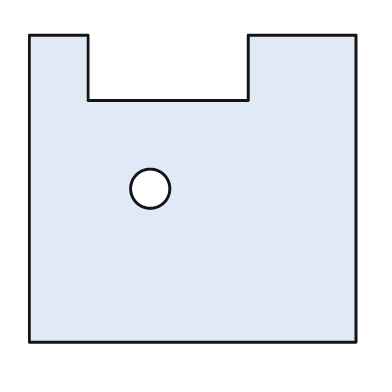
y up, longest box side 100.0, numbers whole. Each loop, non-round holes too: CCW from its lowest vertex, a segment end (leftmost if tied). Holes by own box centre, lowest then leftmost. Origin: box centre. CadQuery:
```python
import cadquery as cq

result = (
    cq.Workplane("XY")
    .moveTo(-50.0, -47.0)
    .lineTo(50.0, -47.0)
    .lineTo(50.0, 47.0)
    .lineTo(17.0, 47.0)
    .lineTo(17.0, 27.0)
    .lineTo(-32.0, 27.0)
    .lineTo(-32.0, 47.0)
    .lineTo(-50.0, 47.0)
    .close()
    .moveTo(-13.0, 0.0)
    .circle(6.0)
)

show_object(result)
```